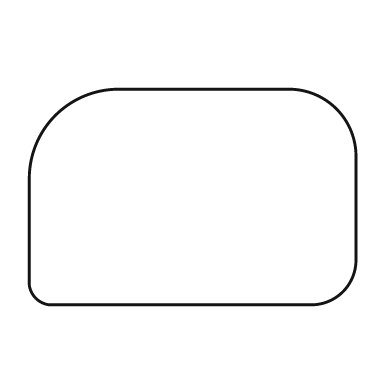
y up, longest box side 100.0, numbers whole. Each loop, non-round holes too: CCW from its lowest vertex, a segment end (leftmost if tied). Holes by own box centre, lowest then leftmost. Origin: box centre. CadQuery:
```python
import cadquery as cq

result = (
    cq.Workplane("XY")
    .moveTo(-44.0, -33.0)
    .lineTo(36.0, -33.0)
    .threePointArc((46.0, -29.0), (50.0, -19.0))
    .lineTo(50.0, 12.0)
    .threePointArc((44.0, 27.0), (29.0, 33.0))
    .lineTo(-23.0, 33.0)
    .threePointArc((-42.0, 25.0), (-50.0, 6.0))
    .lineTo(-50.0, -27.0)
    .threePointArc((-48.0, -31.0), (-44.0, -33.0))
    .close()
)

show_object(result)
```